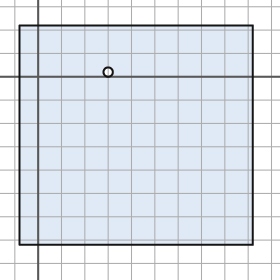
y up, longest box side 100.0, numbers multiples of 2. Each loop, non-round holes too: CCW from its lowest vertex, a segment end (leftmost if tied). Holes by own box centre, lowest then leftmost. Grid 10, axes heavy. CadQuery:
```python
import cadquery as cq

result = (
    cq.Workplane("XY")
    .moveTo(-8.0, -72.0)
    .lineTo(92.0, -72.0)
    .lineTo(92.0, 22.0)
    .lineTo(-8.0, 22.0)
    .close()
    .moveTo(30.0, 2.0)
    .circle(2.0)
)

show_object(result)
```